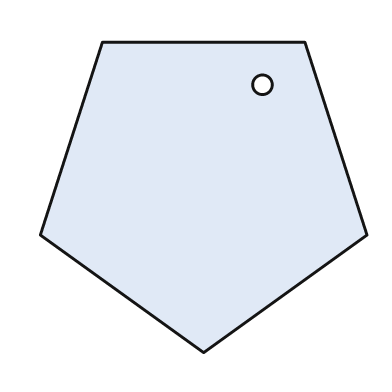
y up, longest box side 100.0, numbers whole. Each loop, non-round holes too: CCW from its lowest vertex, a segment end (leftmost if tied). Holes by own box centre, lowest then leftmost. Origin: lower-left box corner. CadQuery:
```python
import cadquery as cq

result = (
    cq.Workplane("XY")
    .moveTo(50.0, 0.0)
    .lineTo(100.0, 36.0)
    .lineTo(81.0, 95.0)
    .lineTo(19.0, 95.0)
    .lineTo(0.0, 36.0)
    .close()
    .moveTo(68.0, 82.0)
    .circle(3.0)
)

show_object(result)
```